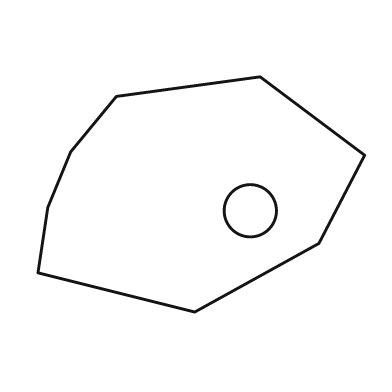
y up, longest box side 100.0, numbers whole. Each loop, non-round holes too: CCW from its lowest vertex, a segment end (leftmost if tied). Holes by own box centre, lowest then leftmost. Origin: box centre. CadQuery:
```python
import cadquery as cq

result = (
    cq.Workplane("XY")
    .moveTo(-2.0, -36.0)
    .lineTo(36.0, -15.0)
    .lineTo(50.0, 12.0)
    .lineTo(18.0, 36.0)
    .lineTo(-26.0, 30.0)
    .lineTo(-40.0, 13.0)
    .lineTo(-47.0, -4.0)
    .lineTo(-50.0, -24.0)
    .close()
    .moveTo(15.0, -5.0)
    .circle(8.0)
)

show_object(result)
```